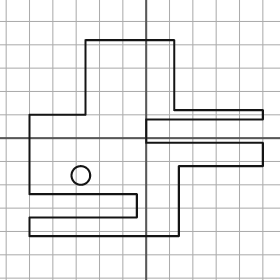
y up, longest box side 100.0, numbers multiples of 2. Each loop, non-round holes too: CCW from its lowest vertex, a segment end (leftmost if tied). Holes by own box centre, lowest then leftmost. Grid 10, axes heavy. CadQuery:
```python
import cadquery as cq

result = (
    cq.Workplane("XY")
    .moveTo(-50.0, -42.0)
    .lineTo(14.0, -42.0)
    .lineTo(14.0, -12.0)
    .lineTo(50.0, -12.0)
    .lineTo(50.0, -2.0)
    .lineTo(0.0, -2.0)
    .lineTo(0.0, 8.0)
    .lineTo(50.0, 8.0)
    .lineTo(50.0, 12.0)
    .lineTo(12.0, 12.0)
    .lineTo(12.0, 42.0)
    .lineTo(-26.0, 42.0)
    .lineTo(-26.0, 10.0)
    .lineTo(-50.0, 10.0)
    .lineTo(-50.0, -24.0)
    .lineTo(-4.0, -24.0)
    .lineTo(-4.0, -34.0)
    .lineTo(-50.0, -34.0)
    .close()
    .moveTo(-28.0, -16.0)
    .circle(4.0)
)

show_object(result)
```